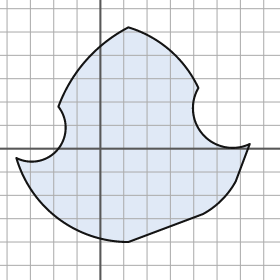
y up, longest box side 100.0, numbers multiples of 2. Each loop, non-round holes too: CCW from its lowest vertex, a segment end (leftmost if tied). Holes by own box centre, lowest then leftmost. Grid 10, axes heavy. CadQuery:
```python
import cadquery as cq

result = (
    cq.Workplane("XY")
    .moveTo(12.0, -40.0)
    .lineTo(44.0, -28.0)
    .threePointArc((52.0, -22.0), (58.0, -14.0))
    .lineTo(64.0, 2.0)
    .threePointArc((44.0, 6.0), (42.0, 26.0))
    .threePointArc((30.0, 42.0), (12.0, 52.0))
    .threePointArc((-6.0, 38.0), (-18.0, 18.0))
    .threePointArc((-18.0, 0.0), (-36.0, -4.0))
    .threePointArc((-18.0, -30.0), (12.0, -40.0))
    .close()
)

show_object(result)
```